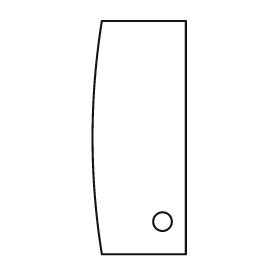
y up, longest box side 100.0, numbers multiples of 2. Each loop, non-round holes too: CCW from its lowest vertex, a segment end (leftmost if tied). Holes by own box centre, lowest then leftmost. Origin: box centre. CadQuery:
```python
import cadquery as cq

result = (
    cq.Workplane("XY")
    .moveTo(-16.0, -50.0)
    .lineTo(20.0, -50.0)
    .lineTo(20.0, 50.0)
    .lineTo(-16.0, 50.0)
    .threePointArc((-20.0, 0.0), (-16.0, -50.0))
    .close()
    .moveTo(10.0, -36.0)
    .circle(4.0)
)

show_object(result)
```